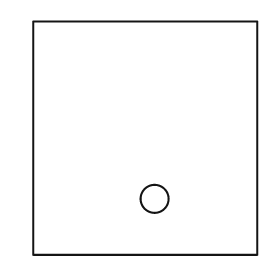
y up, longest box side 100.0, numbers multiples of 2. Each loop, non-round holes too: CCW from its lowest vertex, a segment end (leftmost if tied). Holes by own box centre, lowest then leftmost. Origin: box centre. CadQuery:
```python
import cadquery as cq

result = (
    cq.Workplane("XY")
    .moveTo(-48.0, -50.0)
    .lineTo(48.0, -50.0)
    .lineTo(48.0, 50.0)
    .lineTo(-48.0, 50.0)
    .close()
    .moveTo(4.0, -26.0)
    .circle(6.0)
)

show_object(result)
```